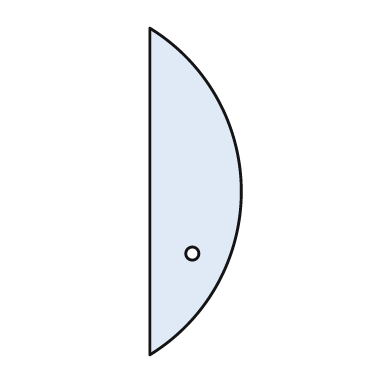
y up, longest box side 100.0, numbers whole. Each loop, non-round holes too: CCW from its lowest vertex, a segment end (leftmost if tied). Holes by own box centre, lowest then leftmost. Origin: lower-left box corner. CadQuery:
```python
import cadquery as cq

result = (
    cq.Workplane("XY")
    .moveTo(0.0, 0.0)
    .threePointArc((28.0, 50.0), (0.0, 100.0))
    .close()
    .moveTo(13.0, 31.0)
    .circle(2.0)
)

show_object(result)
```